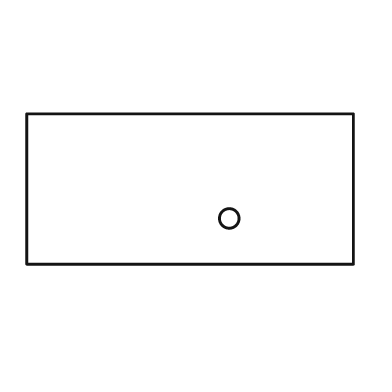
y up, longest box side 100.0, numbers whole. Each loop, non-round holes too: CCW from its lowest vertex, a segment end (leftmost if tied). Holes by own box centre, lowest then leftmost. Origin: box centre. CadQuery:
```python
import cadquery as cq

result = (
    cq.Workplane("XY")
    .moveTo(-50.0, -23.0)
    .lineTo(50.0, -23.0)
    .lineTo(50.0, 23.0)
    .lineTo(-50.0, 23.0)
    .close()
    .moveTo(12.0, -9.0)
    .circle(3.0)
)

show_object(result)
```